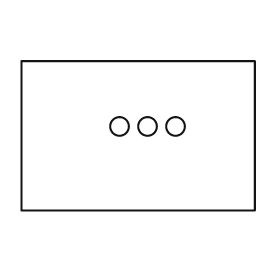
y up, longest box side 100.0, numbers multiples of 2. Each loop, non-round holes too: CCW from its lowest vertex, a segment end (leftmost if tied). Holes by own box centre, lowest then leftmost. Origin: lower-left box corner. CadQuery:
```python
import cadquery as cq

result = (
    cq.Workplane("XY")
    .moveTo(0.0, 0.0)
    .lineTo(100.0, 0.0)
    .lineTo(100.0, 64.0)
    .lineTo(0.0, 64.0)
    .close()
    .moveTo(42.0, 36.0)
    .circle(4.0)
    .moveTo(54.0, 36.0)
    .circle(4.0)
    .moveTo(66.0, 36.0)
    .circle(4.0)
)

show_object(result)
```